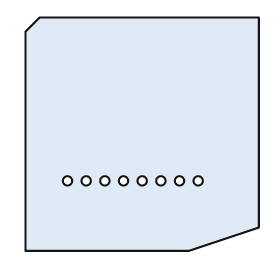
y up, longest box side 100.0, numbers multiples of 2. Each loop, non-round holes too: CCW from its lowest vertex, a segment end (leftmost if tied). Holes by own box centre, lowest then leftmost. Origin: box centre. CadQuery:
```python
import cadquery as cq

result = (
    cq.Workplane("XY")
    .moveTo(-50.0, -50.0)
    .lineTo(20.0, -50.0)
    .lineTo(50.0, -40.0)
    .lineTo(50.0, 50.0)
    .lineTo(-44.0, 50.0)
    .lineTo(-50.0, 44.0)
    .close()
    .moveTo(-32.0, -20.0)
    .circle(2.0)
    .moveTo(-24.0, -20.0)
    .circle(2.0)
    .moveTo(-16.0, -20.0)
    .circle(2.0)
    .moveTo(-8.0, -20.0)
    .circle(2.0)
    .moveTo(0.0, -20.0)
    .circle(2.0)
    .moveTo(8.0, -20.0)
    .circle(2.0)
    .moveTo(16.0, -20.0)
    .circle(2.0)
    .moveTo(24.0, -20.0)
    .circle(2.0)
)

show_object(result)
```